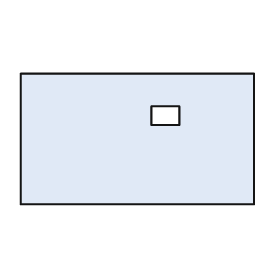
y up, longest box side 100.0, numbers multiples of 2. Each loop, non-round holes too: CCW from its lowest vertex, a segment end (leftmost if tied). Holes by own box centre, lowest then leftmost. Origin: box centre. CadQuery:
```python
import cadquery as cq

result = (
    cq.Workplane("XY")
    .moveTo(-50.0, -28.0)
    .lineTo(50.0, -28.0)
    .lineTo(50.0, 28.0)
    .lineTo(-50.0, 28.0)
    .close()
    .moveTo(6.0, 6.0)
    .lineTo(18.0, 6.0)
    .lineTo(18.0, 14.0)
    .lineTo(6.0, 14.0)
    .close()
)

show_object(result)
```